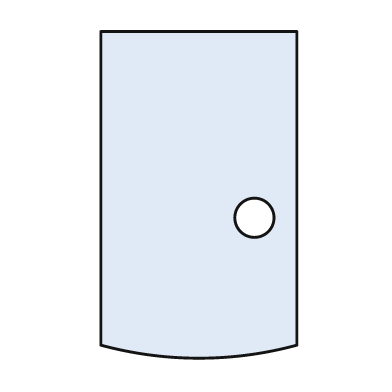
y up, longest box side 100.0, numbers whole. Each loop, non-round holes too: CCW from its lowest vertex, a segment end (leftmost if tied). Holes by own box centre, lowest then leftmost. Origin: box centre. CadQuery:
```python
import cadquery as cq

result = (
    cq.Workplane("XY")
    .moveTo(-30.0, -46.0)
    .threePointArc((0.0, -50.0), (30.0, -46.0))
    .lineTo(30.0, 50.0)
    .lineTo(-30.0, 50.0)
    .close()
    .moveTo(17.0, -7.0)
    .circle(6.0)
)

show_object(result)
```